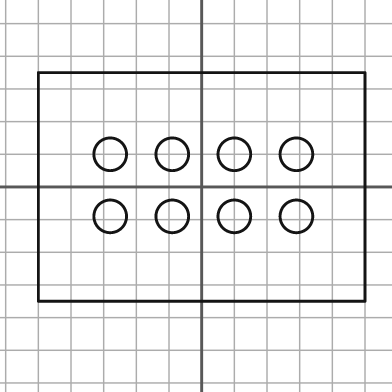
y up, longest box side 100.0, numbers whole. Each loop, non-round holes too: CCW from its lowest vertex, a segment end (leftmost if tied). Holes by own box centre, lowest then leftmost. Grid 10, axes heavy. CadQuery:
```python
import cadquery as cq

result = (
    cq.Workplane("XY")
    .moveTo(-50.0, -35.0)
    .lineTo(50.0, -35.0)
    .lineTo(50.0, 35.0)
    .lineTo(-50.0, 35.0)
    .close()
    .moveTo(-28.0, -9.0)
    .circle(5.0)
    .moveTo(-9.0, -9.0)
    .circle(5.0)
    .moveTo(10.0, -9.0)
    .circle(5.0)
    .moveTo(29.0, -9.0)
    .circle(5.0)
    .moveTo(-28.0, 10.0)
    .circle(5.0)
    .moveTo(-9.0, 10.0)
    .circle(5.0)
    .moveTo(10.0, 10.0)
    .circle(5.0)
    .moveTo(29.0, 10.0)
    .circle(5.0)
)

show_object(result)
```